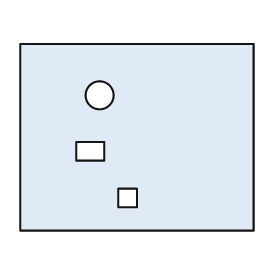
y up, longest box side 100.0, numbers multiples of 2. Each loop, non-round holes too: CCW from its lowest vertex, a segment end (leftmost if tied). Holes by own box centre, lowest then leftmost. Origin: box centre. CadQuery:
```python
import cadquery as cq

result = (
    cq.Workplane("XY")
    .moveTo(-50.0, -40.0)
    .lineTo(50.0, -40.0)
    .lineTo(50.0, 40.0)
    .lineTo(-50.0, 40.0)
    .close()
    .moveTo(-8.0, -30.0)
    .lineTo(0.0, -30.0)
    .lineTo(0.0, -22.0)
    .lineTo(-8.0, -22.0)
    .close()
    .moveTo(-26.0, -10.0)
    .lineTo(-14.0, -10.0)
    .lineTo(-14.0, -2.0)
    .lineTo(-26.0, -2.0)
    .close()
    .moveTo(-16.0, 18.0)
    .circle(6.0)
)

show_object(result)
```